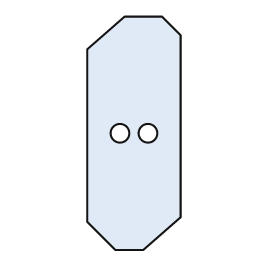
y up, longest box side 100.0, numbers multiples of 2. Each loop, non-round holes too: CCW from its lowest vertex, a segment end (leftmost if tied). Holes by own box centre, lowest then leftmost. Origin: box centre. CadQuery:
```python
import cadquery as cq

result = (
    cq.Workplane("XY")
    .moveTo(-8.0, -50.0)
    .lineTo(4.0, -50.0)
    .lineTo(20.0, -36.0)
    .lineTo(20.0, 42.0)
    .lineTo(12.0, 50.0)
    .lineTo(-4.0, 50.0)
    .lineTo(-20.0, 36.0)
    .lineTo(-20.0, -38.0)
    .close()
    .moveTo(-6.0, 0.0)
    .circle(4.0)
    .moveTo(6.0, 0.0)
    .circle(4.0)
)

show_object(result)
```